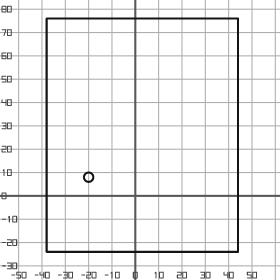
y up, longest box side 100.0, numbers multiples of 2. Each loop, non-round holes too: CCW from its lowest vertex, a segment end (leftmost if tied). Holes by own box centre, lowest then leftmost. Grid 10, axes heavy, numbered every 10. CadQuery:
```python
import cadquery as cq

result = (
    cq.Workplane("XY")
    .moveTo(-38.0, -24.0)
    .lineTo(44.0, -24.0)
    .lineTo(44.0, 76.0)
    .lineTo(-38.0, 76.0)
    .close()
    .moveTo(-20.0, 8.0)
    .circle(2.0)
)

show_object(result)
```